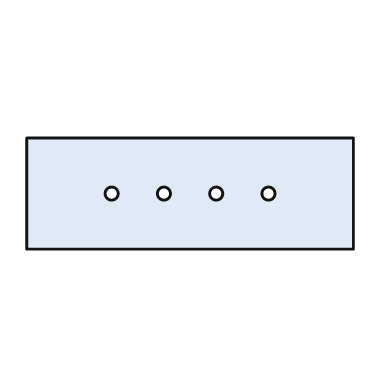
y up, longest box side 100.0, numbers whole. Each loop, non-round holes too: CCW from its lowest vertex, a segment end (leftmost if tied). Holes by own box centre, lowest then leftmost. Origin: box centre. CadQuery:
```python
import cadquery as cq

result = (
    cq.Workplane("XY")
    .moveTo(-50.0, -17.0)
    .lineTo(50.0, -17.0)
    .lineTo(50.0, 17.0)
    .lineTo(-50.0, 17.0)
    .close()
    .moveTo(-24.0, 0.0)
    .circle(2.0)
    .moveTo(-8.0, 0.0)
    .circle(2.0)
    .moveTo(8.0, 0.0)
    .circle(2.0)
    .moveTo(24.0, 0.0)
    .circle(2.0)
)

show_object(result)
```